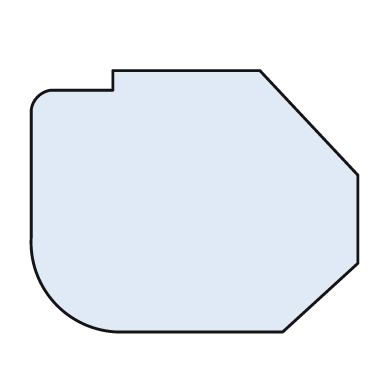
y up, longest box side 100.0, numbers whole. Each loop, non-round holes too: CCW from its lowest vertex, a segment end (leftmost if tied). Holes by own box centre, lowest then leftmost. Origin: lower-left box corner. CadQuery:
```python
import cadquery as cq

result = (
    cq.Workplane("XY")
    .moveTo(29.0, 0.0)
    .lineTo(77.0, 0.0)
    .lineTo(100.0, 21.0)
    .lineTo(100.0, 48.0)
    .lineTo(70.0, 80.0)
    .lineTo(25.0, 80.0)
    .lineTo(25.0, 74.0)
    .lineTo(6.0, 74.0)
    .threePointArc((2.0, 72.0), (0.0, 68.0))
    .lineTo(0.0, 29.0)
    .threePointArc((8.0, 8.0), (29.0, 0.0))
    .close()
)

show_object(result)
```